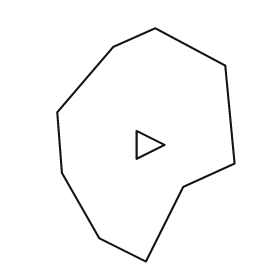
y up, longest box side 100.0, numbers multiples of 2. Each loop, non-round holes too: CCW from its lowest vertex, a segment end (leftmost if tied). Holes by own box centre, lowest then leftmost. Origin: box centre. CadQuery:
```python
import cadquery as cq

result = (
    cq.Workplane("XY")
    .moveTo(0.0, -50.0)
    .lineTo(16.0, -18.0)
    .lineTo(38.0, -8.0)
    .lineTo(34.0, 34.0)
    .lineTo(4.0, 50.0)
    .lineTo(-14.0, 42.0)
    .lineTo(-38.0, 14.0)
    .lineTo(-36.0, -12.0)
    .lineTo(-20.0, -40.0)
    .close()
    .moveTo(-4.0, -6.0)
    .lineTo(8.0, 0.0)
    .lineTo(-4.0, 6.0)
    .close()
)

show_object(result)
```